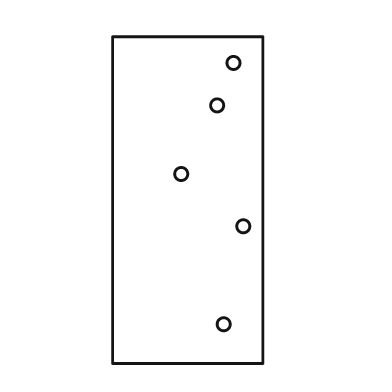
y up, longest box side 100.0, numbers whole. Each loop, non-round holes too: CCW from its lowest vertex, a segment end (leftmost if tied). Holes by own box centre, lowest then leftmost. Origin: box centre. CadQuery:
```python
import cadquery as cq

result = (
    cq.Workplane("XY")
    .moveTo(-23.0, -50.0)
    .lineTo(23.0, -50.0)
    .lineTo(23.0, 50.0)
    .lineTo(-23.0, 50.0)
    .close()
    .moveTo(11.0, -38.0)
    .circle(2.0)
    .moveTo(17.0, -8.0)
    .circle(2.0)
    .moveTo(-2.0, 8.0)
    .circle(2.0)
    .moveTo(9.0, 29.0)
    .circle(2.0)
    .moveTo(14.0, 42.0)
    .circle(2.0)
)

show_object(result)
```